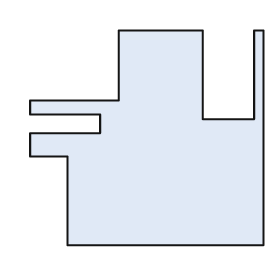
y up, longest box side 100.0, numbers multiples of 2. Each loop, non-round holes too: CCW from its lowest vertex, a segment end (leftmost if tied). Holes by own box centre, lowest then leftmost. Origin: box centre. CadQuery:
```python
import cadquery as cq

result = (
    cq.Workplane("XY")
    .moveTo(-34.0, -46.0)
    .lineTo(50.0, -46.0)
    .lineTo(50.0, 46.0)
    .lineTo(46.0, 46.0)
    .lineTo(46.0, 8.0)
    .lineTo(24.0, 8.0)
    .lineTo(24.0, 46.0)
    .lineTo(-12.0, 46.0)
    .lineTo(-12.0, 16.0)
    .lineTo(-50.0, 16.0)
    .lineTo(-50.0, 10.0)
    .lineTo(-20.0, 10.0)
    .lineTo(-20.0, 2.0)
    .lineTo(-50.0, 2.0)
    .lineTo(-50.0, -8.0)
    .lineTo(-34.0, -8.0)
    .close()
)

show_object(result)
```